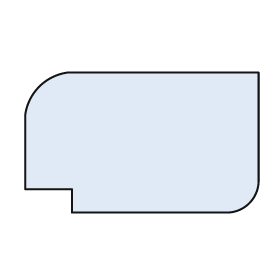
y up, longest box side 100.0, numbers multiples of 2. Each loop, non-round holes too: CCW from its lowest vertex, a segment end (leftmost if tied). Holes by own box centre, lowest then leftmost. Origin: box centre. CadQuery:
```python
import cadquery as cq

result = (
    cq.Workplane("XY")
    .moveTo(-30.0, -30.0)
    .lineTo(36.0, -30.0)
    .threePointArc((46.0, -26.0), (50.0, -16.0))
    .lineTo(50.0, 30.0)
    .lineTo(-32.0, 30.0)
    .threePointArc((-44.0, 24.0), (-50.0, 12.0))
    .lineTo(-50.0, -20.0)
    .lineTo(-30.0, -20.0)
    .close()
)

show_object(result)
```